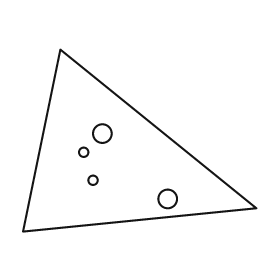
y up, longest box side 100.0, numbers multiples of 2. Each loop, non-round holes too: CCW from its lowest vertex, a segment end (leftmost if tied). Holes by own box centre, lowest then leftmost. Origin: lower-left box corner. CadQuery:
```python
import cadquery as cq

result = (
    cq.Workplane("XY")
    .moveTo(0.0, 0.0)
    .lineTo(100.0, 10.0)
    .lineTo(16.0, 78.0)
    .close()
    .moveTo(62.0, 14.0)
    .circle(4.0)
    .moveTo(30.0, 22.0)
    .circle(2.0)
    .moveTo(26.0, 34.0)
    .circle(2.0)
    .moveTo(34.0, 42.0)
    .circle(4.0)
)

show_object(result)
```